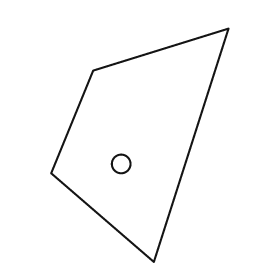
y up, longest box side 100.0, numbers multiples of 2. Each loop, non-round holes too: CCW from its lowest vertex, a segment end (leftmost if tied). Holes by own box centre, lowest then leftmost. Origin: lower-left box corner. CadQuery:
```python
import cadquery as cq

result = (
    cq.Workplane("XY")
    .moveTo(44.0, 0.0)
    .lineTo(76.0, 100.0)
    .lineTo(18.0, 82.0)
    .lineTo(0.0, 38.0)
    .close()
    .moveTo(30.0, 42.0)
    .circle(4.0)
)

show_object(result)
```